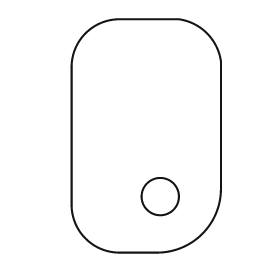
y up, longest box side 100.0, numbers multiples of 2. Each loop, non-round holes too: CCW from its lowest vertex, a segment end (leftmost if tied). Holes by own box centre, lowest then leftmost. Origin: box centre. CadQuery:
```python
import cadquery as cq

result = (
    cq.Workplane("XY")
    .moveTo(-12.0, -50.0)
    .lineTo(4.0, -50.0)
    .threePointArc((24.0, -42.0), (32.0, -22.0))
    .lineTo(32.0, 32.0)
    .threePointArc((26.0, 44.0), (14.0, 50.0))
    .lineTo(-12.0, 50.0)
    .threePointArc((-26.0, 44.0), (-32.0, 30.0))
    .lineTo(-32.0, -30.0)
    .threePointArc((-26.0, -44.0), (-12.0, -50.0))
    .close()
    .moveTo(6.0, -26.0)
    .circle(8.0)
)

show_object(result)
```